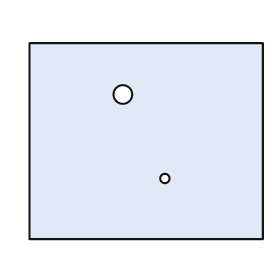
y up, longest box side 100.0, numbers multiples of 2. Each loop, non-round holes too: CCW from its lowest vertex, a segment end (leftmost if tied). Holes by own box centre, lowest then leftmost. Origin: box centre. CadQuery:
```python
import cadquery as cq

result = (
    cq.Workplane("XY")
    .moveTo(-50.0, -42.0)
    .lineTo(50.0, -42.0)
    .lineTo(50.0, 42.0)
    .lineTo(-50.0, 42.0)
    .close()
    .moveTo(8.0, -16.0)
    .circle(2.0)
    .moveTo(-10.0, 20.0)
    .circle(4.0)
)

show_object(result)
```